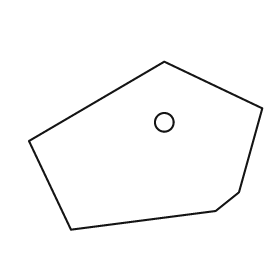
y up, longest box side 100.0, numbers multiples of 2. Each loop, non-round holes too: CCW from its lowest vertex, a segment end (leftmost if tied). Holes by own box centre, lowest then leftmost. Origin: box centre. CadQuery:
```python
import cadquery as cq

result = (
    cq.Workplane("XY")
    .moveTo(-32.0, -36.0)
    .lineTo(30.0, -28.0)
    .lineTo(40.0, -20.0)
    .lineTo(50.0, 16.0)
    .lineTo(8.0, 36.0)
    .lineTo(-50.0, 2.0)
    .close()
    .moveTo(8.0, 10.0)
    .circle(4.0)
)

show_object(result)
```